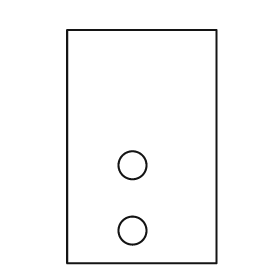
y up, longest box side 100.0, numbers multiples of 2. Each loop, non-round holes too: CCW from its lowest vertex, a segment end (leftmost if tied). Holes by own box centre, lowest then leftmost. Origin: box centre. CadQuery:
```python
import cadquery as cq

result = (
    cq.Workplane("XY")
    .moveTo(-32.0, -50.0)
    .lineTo(32.0, -50.0)
    .lineTo(32.0, 50.0)
    .lineTo(-32.0, 50.0)
    .close()
    .moveTo(-4.0, -36.0)
    .circle(6.0)
    .moveTo(-4.0, -8.0)
    .circle(6.0)
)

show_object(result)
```